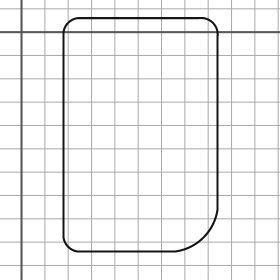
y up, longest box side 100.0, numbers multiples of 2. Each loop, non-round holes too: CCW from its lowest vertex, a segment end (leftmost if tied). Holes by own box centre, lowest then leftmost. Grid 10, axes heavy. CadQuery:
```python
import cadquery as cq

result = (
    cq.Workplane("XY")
    .moveTo(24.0, -94.0)
    .lineTo(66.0, -94.0)
    .threePointArc((78.0, -88.0), (84.0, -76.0))
    .lineTo(84.0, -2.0)
    .threePointArc((82.0, 4.0), (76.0, 6.0))
    .lineTo(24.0, 6.0)
    .threePointArc((20.0, 4.0), (18.0, 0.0))
    .lineTo(18.0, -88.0)
    .threePointArc((20.0, -92.0), (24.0, -94.0))
    .close()
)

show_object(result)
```